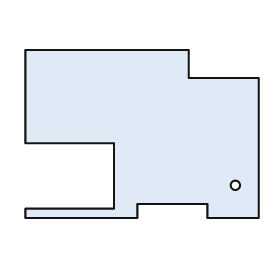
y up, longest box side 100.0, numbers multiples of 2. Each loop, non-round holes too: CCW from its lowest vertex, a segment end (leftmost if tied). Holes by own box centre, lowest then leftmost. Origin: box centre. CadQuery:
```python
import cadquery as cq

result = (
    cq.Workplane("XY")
    .moveTo(-50.0, -36.0)
    .lineTo(-2.0, -36.0)
    .lineTo(-2.0, -30.0)
    .lineTo(28.0, -30.0)
    .lineTo(28.0, -36.0)
    .lineTo(50.0, -36.0)
    .lineTo(50.0, 24.0)
    .lineTo(20.0, 24.0)
    .lineTo(20.0, 36.0)
    .lineTo(-50.0, 36.0)
    .lineTo(-50.0, -4.0)
    .lineTo(-12.0, -4.0)
    .lineTo(-12.0, -32.0)
    .lineTo(-50.0, -32.0)
    .close()
    .moveTo(40.0, -22.0)
    .circle(2.0)
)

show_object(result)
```